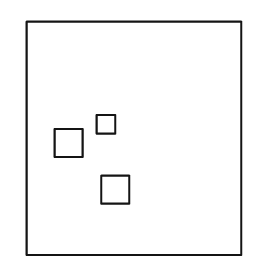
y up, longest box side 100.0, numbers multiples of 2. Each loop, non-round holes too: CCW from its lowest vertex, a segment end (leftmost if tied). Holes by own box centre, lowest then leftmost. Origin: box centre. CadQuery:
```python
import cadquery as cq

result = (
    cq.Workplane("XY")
    .moveTo(-46.0, -50.0)
    .lineTo(46.0, -50.0)
    .lineTo(46.0, 50.0)
    .lineTo(-46.0, 50.0)
    .close()
    .moveTo(-14.0, -28.0)
    .lineTo(-2.0, -28.0)
    .lineTo(-2.0, -16.0)
    .lineTo(-14.0, -16.0)
    .close()
    .moveTo(-34.0, -8.0)
    .lineTo(-22.0, -8.0)
    .lineTo(-22.0, 4.0)
    .lineTo(-34.0, 4.0)
    .close()
    .moveTo(-16.0, 2.0)
    .lineTo(-8.0, 2.0)
    .lineTo(-8.0, 10.0)
    .lineTo(-16.0, 10.0)
    .close()
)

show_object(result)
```